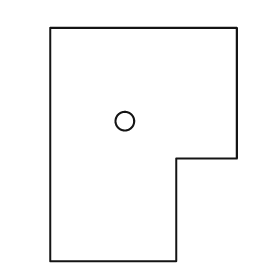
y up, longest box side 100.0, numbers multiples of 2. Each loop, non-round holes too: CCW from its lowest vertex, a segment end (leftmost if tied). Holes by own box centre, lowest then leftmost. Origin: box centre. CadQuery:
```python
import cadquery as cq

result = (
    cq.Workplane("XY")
    .moveTo(-40.0, -50.0)
    .lineTo(14.0, -50.0)
    .lineTo(14.0, -6.0)
    .lineTo(40.0, -6.0)
    .lineTo(40.0, 50.0)
    .lineTo(-40.0, 50.0)
    .close()
    .moveTo(-8.0, 10.0)
    .circle(4.0)
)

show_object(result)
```